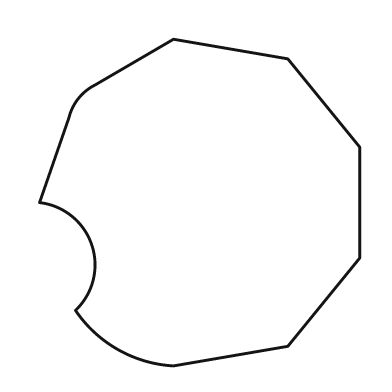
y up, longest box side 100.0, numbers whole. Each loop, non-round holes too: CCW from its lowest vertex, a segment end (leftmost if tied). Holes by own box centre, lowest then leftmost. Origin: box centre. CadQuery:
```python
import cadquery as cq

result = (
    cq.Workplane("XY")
    .moveTo(-8.0, -50.0)
    .lineTo(27.0, -44.0)
    .lineTo(49.0, -17.0)
    .lineTo(49.0, 17.0)
    .lineTo(27.0, 44.0)
    .lineTo(-8.0, 50.0)
    .lineTo(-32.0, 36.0)
    .threePointArc((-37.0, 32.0), (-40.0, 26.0))
    .lineTo(-49.0, 0.0)
    .threePointArc((-33.0, -13.0), (-38.0, -33.0))
    .threePointArc((-25.0, -45.0), (-8.0, -50.0))
    .close()
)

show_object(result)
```